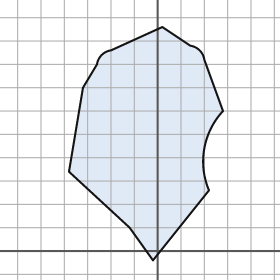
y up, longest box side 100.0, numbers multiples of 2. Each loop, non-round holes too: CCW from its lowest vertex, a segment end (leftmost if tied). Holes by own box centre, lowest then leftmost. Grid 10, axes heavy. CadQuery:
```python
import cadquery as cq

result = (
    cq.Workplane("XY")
    .moveTo(-2.0, -4.0)
    .lineTo(22.0, 26.0)
    .threePointArc((20.0, 44.0), (28.0, 60.0))
    .lineTo(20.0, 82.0)
    .threePointArc((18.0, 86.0), (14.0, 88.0))
    .lineTo(2.0, 96.0)
    .lineTo(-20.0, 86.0)
    .threePointArc((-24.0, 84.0), (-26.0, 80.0))
    .lineTo(-32.0, 70.0)
    .lineTo(-38.0, 34.0)
    .lineTo(-12.0, 10.0)
    .close()
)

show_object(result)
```